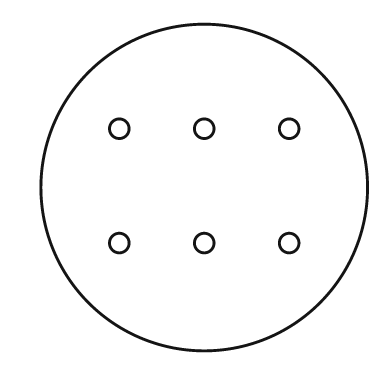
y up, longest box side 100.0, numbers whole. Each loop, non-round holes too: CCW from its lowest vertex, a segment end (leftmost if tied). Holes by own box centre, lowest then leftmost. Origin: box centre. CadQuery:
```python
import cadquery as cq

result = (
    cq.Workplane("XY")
    .moveTo(0.0, 0.0)
    .circle(50.0)
    .moveTo(-26.0, -17.0)
    .circle(3.0)
    .moveTo(0.0, -17.0)
    .circle(3.0)
    .moveTo(26.0, -17.0)
    .circle(3.0)
    .moveTo(-26.0, 18.0)
    .circle(3.0)
    .moveTo(0.0, 18.0)
    .circle(3.0)
    .moveTo(26.0, 18.0)
    .circle(3.0)
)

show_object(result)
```